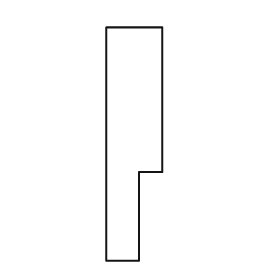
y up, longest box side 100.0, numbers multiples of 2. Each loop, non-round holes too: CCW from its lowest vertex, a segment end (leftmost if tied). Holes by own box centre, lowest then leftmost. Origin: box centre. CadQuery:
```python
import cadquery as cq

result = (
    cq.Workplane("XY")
    .moveTo(-12.0, -50.0)
    .lineTo(2.0, -50.0)
    .lineTo(2.0, -12.0)
    .lineTo(12.0, -12.0)
    .lineTo(12.0, 50.0)
    .lineTo(-12.0, 50.0)
    .close()
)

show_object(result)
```